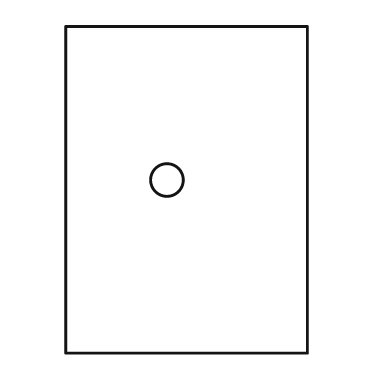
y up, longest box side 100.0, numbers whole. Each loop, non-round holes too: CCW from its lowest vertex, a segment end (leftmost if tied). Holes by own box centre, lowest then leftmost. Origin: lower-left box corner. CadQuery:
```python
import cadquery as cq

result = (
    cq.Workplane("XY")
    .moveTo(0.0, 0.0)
    .lineTo(74.0, 0.0)
    .lineTo(74.0, 100.0)
    .lineTo(0.0, 100.0)
    .close()
    .moveTo(31.0, 53.0)
    .circle(5.0)
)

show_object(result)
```